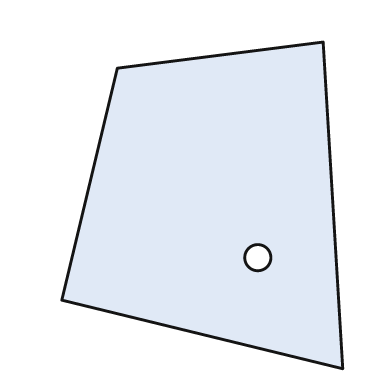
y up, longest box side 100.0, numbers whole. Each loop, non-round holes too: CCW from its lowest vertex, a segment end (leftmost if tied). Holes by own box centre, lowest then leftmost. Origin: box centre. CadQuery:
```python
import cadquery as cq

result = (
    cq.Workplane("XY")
    .moveTo(43.0, -50.0)
    .lineTo(37.0, 50.0)
    .lineTo(-26.0, 42.0)
    .lineTo(-43.0, -29.0)
    .close()
    .moveTo(17.0, -16.0)
    .circle(4.0)
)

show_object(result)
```